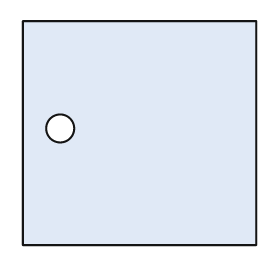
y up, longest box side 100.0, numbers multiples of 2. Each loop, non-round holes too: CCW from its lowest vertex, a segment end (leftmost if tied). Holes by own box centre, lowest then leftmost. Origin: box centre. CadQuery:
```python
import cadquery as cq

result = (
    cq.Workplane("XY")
    .moveTo(-50.0, -48.0)
    .lineTo(50.0, -48.0)
    .lineTo(50.0, 48.0)
    .lineTo(-50.0, 48.0)
    .close()
    .moveTo(-34.0, 2.0)
    .circle(6.0)
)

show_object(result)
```